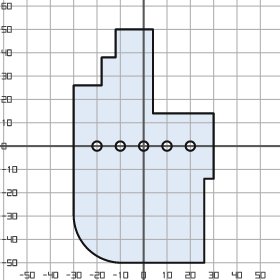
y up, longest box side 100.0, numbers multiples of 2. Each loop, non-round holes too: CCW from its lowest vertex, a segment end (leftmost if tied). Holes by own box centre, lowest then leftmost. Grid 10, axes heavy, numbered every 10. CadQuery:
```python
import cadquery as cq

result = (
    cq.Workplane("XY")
    .moveTo(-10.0, -50.0)
    .lineTo(26.0, -50.0)
    .lineTo(26.0, -14.0)
    .lineTo(30.0, -14.0)
    .lineTo(30.0, 14.0)
    .lineTo(4.0, 14.0)
    .lineTo(4.0, 50.0)
    .lineTo(-12.0, 50.0)
    .lineTo(-12.0, 38.0)
    .lineTo(-18.0, 38.0)
    .lineTo(-18.0, 26.0)
    .lineTo(-30.0, 26.0)
    .lineTo(-30.0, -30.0)
    .threePointArc((-24.0, -44.0), (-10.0, -50.0))
    .close()
    .moveTo(-20.0, 0.0)
    .circle(2.0)
    .moveTo(-10.0, 0.0)
    .circle(2.0)
    .moveTo(0.0, 0.0)
    .circle(2.0)
    .moveTo(10.0, 0.0)
    .circle(2.0)
    .moveTo(20.0, 0.0)
    .circle(2.0)
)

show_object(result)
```